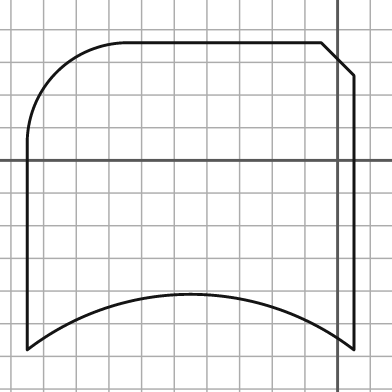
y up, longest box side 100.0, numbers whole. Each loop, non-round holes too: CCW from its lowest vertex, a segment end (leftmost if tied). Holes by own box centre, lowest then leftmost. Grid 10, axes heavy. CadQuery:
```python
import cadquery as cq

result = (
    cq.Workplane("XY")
    .moveTo(-95.0, -58.0)
    .threePointArc((-45.0, -41.0), (5.0, -58.0))
    .lineTo(5.0, 26.0)
    .lineTo(-5.0, 36.0)
    .lineTo(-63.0, 36.0)
    .threePointArc((-86.0, 27.0), (-95.0, 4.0))
    .close()
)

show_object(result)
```